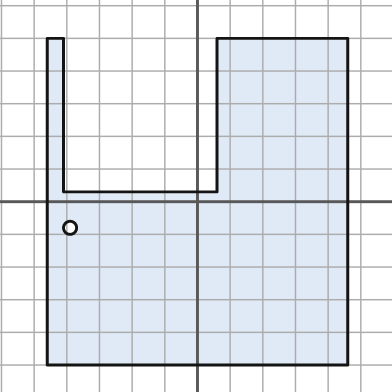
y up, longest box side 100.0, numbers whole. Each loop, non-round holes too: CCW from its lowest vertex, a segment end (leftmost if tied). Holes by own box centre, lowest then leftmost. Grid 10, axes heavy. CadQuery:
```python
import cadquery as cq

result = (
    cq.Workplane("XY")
    .moveTo(-46.0, -50.0)
    .lineTo(46.0, -50.0)
    .lineTo(46.0, 50.0)
    .lineTo(6.0, 50.0)
    .lineTo(6.0, 3.0)
    .lineTo(-41.0, 3.0)
    .lineTo(-41.0, 50.0)
    .lineTo(-46.0, 50.0)
    .close()
    .moveTo(-39.0, -8.0)
    .circle(2.0)
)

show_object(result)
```